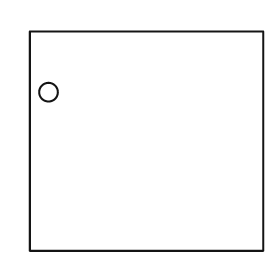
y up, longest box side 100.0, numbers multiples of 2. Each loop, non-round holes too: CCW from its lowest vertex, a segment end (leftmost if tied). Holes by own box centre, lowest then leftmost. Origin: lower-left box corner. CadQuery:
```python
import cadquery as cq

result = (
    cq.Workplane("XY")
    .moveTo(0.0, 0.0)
    .lineTo(100.0, 0.0)
    .lineTo(100.0, 94.0)
    .lineTo(0.0, 94.0)
    .close()
    .moveTo(8.0, 68.0)
    .circle(4.0)
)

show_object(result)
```